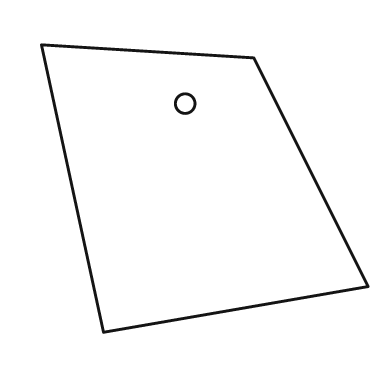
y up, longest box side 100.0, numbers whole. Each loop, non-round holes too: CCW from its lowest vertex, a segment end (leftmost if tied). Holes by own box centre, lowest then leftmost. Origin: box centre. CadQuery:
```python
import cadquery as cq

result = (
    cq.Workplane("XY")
    .moveTo(-31.0, -44.0)
    .lineTo(50.0, -30.0)
    .lineTo(15.0, 40.0)
    .lineTo(-50.0, 44.0)
    .close()
    .moveTo(-6.0, 26.0)
    .circle(3.0)
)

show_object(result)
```